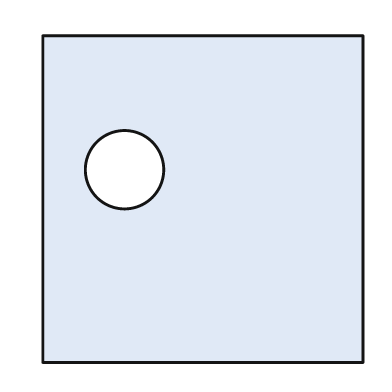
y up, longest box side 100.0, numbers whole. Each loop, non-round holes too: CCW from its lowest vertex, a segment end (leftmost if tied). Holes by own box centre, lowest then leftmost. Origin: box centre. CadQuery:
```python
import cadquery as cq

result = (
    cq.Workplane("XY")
    .moveTo(-49.0, -50.0)
    .lineTo(49.0, -50.0)
    .lineTo(49.0, 50.0)
    .lineTo(-49.0, 50.0)
    .close()
    .moveTo(-24.0, 9.0)
    .circle(12.0)
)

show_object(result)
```